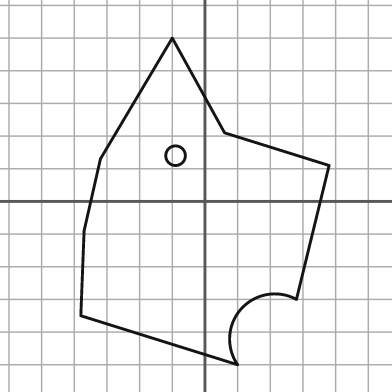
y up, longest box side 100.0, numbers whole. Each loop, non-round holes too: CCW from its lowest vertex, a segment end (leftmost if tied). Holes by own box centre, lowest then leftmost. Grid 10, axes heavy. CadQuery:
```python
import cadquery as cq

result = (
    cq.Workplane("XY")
    .moveTo(10.0, -50.0)
    .threePointArc((11.0, -33.0), (28.0, -30.0))
    .lineTo(38.0, 11.0)
    .lineTo(6.0, 21.0)
    .lineTo(-10.0, 50.0)
    .lineTo(-32.0, 13.0)
    .lineTo(-37.0, -9.0)
    .lineTo(-38.0, -35.0)
    .close()
    .moveTo(-9.0, 14.0)
    .circle(3.0)
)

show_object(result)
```